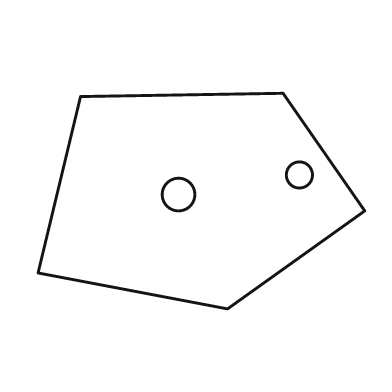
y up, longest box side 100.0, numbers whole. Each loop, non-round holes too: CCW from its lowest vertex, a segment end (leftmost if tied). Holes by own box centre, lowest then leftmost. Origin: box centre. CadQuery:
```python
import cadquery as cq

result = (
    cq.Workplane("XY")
    .moveTo(8.0, -33.0)
    .lineTo(50.0, -3.0)
    .lineTo(25.0, 33.0)
    .lineTo(-37.0, 32.0)
    .lineTo(-50.0, -22.0)
    .close()
    .moveTo(-7.0, 2.0)
    .circle(5.0)
    .moveTo(30.0, 8.0)
    .circle(4.0)
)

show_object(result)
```